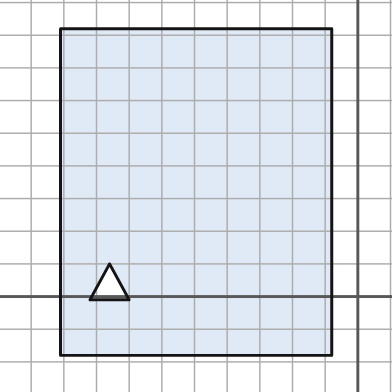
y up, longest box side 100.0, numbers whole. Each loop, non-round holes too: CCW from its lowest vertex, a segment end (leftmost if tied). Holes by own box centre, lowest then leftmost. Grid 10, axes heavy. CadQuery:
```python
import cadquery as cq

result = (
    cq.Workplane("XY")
    .moveTo(-91.0, -18.0)
    .lineTo(-8.0, -18.0)
    .lineTo(-8.0, 82.0)
    .lineTo(-91.0, 82.0)
    .close()
    .moveTo(-82.0, -1.0)
    .lineTo(-70.0, -1.0)
    .lineTo(-76.0, 10.0)
    .close()
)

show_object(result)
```